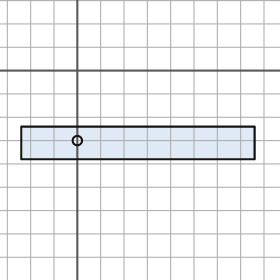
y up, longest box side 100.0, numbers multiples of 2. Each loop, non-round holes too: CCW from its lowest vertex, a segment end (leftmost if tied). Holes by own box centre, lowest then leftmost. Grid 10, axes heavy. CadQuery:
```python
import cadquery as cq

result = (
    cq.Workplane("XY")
    .moveTo(-24.0, -38.0)
    .lineTo(76.0, -38.0)
    .lineTo(76.0, -24.0)
    .lineTo(-24.0, -24.0)
    .close()
    .moveTo(0.0, -30.0)
    .circle(2.0)
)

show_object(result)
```